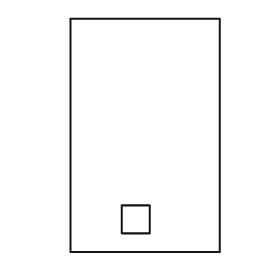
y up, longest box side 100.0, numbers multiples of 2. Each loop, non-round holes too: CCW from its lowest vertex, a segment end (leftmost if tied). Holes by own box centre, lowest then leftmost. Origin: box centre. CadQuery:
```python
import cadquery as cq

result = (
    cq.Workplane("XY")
    .moveTo(-32.0, -50.0)
    .lineTo(32.0, -50.0)
    .lineTo(32.0, 50.0)
    .lineTo(-32.0, 50.0)
    .close()
    .moveTo(-10.0, -42.0)
    .lineTo(2.0, -42.0)
    .lineTo(2.0, -30.0)
    .lineTo(-10.0, -30.0)
    .close()
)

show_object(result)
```